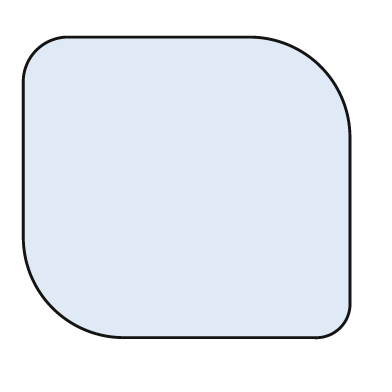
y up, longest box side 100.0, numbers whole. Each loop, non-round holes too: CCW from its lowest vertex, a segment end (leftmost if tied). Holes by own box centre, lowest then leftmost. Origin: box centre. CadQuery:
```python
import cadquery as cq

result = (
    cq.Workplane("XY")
    .moveTo(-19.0, -46.0)
    .lineTo(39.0, -46.0)
    .threePointArc((47.0, -43.0), (50.0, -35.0))
    .lineTo(50.0, 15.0)
    .threePointArc((41.0, 37.0), (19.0, 46.0))
    .lineTo(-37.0, 46.0)
    .threePointArc((-46.0, 42.0), (-50.0, 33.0))
    .lineTo(-50.0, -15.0)
    .threePointArc((-41.0, -37.0), (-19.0, -46.0))
    .close()
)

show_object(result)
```